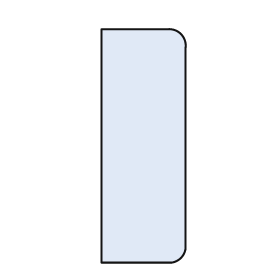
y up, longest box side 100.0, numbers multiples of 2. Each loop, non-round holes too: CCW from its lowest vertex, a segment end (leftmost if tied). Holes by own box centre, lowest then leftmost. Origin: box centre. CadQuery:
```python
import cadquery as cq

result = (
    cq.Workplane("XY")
    .moveTo(-18.0, -50.0)
    .lineTo(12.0, -50.0)
    .threePointArc((16.0, -48.0), (18.0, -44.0))
    .lineTo(18.0, 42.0)
    .threePointArc((16.0, 48.0), (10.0, 50.0))
    .lineTo(-18.0, 50.0)
    .close()
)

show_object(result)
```